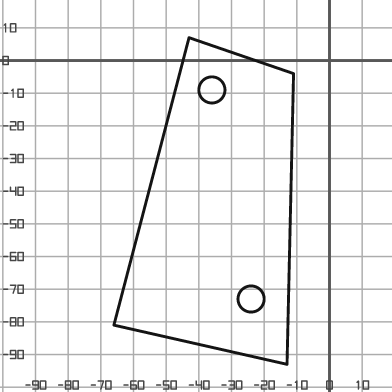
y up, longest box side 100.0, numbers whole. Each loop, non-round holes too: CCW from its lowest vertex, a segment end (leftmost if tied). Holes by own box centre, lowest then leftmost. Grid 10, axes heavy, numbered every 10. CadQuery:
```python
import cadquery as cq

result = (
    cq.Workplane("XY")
    .moveTo(-13.0, -93.0)
    .lineTo(-11.0, -4.0)
    .lineTo(-43.0, 7.0)
    .lineTo(-66.0, -81.0)
    .close()
    .moveTo(-24.0, -73.0)
    .circle(4.0)
    .moveTo(-36.0, -9.0)
    .circle(4.0)
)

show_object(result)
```